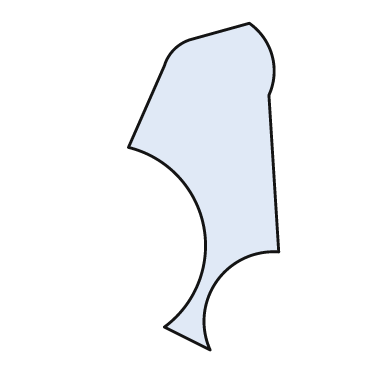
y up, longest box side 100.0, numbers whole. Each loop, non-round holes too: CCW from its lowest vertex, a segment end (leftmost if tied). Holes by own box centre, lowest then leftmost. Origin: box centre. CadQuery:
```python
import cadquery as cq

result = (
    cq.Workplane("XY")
    .moveTo(2.0, -50.0)
    .threePointArc((4.0, -29.0), (23.0, -20.0))
    .lineTo(20.0, 28.0)
    .threePointArc((21.0, 40.0), (14.0, 50.0))
    .lineTo(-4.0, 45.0)
    .threePointArc((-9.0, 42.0), (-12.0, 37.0))
    .lineTo(-23.0, 12.0)
    .threePointArc((0.0, -12.0), (-12.0, -43.0))
    .close()
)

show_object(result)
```